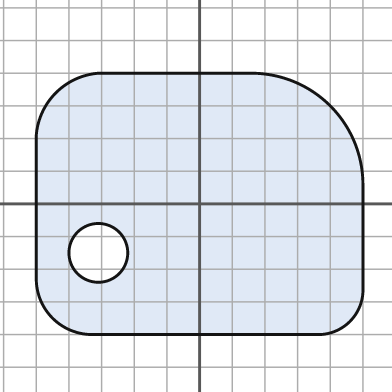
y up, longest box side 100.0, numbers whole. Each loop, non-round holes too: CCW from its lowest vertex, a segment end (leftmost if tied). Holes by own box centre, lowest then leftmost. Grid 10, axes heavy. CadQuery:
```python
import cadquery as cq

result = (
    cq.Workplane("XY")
    .moveTo(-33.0, -40.0)
    .lineTo(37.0, -40.0)
    .threePointArc((46.0, -36.0), (50.0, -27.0))
    .lineTo(50.0, 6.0)
    .threePointArc((40.0, 30.0), (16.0, 40.0))
    .lineTo(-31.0, 40.0)
    .threePointArc((-44.0, 34.0), (-50.0, 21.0))
    .lineTo(-50.0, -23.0)
    .threePointArc((-45.0, -35.0), (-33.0, -40.0))
    .close()
    .moveTo(-31.0, -15.0)
    .circle(9.0)
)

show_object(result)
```